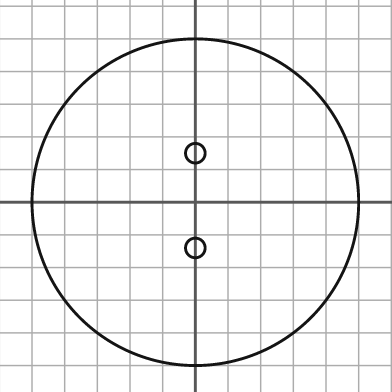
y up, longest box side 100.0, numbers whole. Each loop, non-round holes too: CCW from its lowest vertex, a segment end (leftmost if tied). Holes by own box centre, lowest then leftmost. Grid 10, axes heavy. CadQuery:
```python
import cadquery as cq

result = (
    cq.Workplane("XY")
    .moveTo(0.0, 0.0)
    .circle(50.0)
    .moveTo(0.0, -14.0)
    .circle(3.0)
    .moveTo(0.0, 15.0)
    .circle(3.0)
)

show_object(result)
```